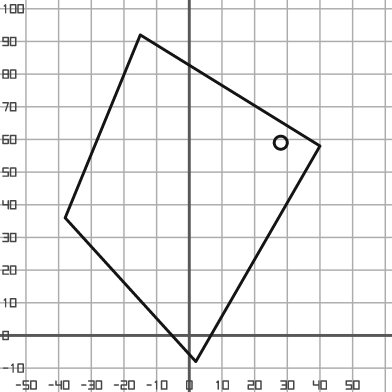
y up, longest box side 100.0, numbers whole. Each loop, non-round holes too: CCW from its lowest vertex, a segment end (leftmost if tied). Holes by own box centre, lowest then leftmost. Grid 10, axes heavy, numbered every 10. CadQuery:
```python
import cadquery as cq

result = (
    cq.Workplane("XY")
    .moveTo(2.0, -8.0)
    .lineTo(40.0, 58.0)
    .lineTo(-15.0, 92.0)
    .lineTo(-38.0, 36.0)
    .close()
    .moveTo(28.0, 59.0)
    .circle(2.0)
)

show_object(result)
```